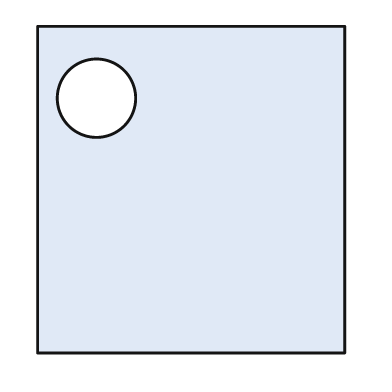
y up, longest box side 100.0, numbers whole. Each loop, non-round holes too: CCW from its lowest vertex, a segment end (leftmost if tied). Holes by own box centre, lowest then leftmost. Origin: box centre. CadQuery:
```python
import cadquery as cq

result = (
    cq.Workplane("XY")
    .moveTo(-47.0, -50.0)
    .lineTo(47.0, -50.0)
    .lineTo(47.0, 50.0)
    .lineTo(-47.0, 50.0)
    .close()
    .moveTo(-29.0, 28.0)
    .circle(12.0)
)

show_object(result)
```